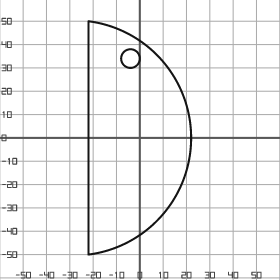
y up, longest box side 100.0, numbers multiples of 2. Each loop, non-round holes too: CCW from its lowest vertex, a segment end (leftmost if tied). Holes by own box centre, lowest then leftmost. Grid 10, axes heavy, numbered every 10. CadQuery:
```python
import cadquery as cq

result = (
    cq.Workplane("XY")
    .moveTo(-22.0, -50.0)
    .threePointArc((22.0, 0.0), (-22.0, 50.0))
    .close()
    .moveTo(-4.0, 34.0)
    .circle(4.0)
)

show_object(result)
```